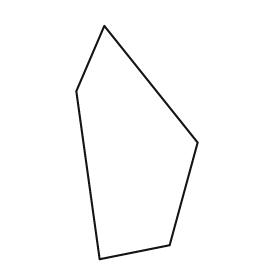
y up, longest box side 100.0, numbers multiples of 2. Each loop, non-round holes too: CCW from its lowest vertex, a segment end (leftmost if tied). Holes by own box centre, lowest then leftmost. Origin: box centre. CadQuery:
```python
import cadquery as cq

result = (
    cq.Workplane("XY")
    .moveTo(-16.0, -50.0)
    .lineTo(14.0, -44.0)
    .lineTo(26.0, 0.0)
    .lineTo(-14.0, 50.0)
    .lineTo(-26.0, 22.0)
    .close()
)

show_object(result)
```